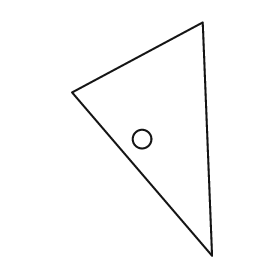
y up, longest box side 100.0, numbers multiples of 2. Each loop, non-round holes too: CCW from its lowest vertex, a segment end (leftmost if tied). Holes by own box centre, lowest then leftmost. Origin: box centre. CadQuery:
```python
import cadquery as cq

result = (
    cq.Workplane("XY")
    .moveTo(30.0, -50.0)
    .lineTo(26.0, 50.0)
    .lineTo(-30.0, 20.0)
    .close()
    .moveTo(0.0, 0.0)
    .circle(4.0)
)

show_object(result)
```